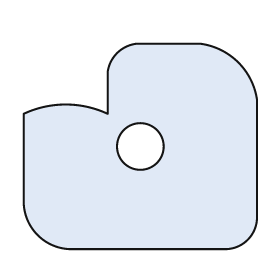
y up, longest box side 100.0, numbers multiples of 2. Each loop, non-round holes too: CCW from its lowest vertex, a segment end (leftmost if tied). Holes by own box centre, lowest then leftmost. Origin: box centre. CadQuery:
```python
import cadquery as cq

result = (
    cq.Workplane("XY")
    .moveTo(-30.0, -44.0)
    .lineTo(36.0, -44.0)
    .threePointArc((46.0, -40.0), (50.0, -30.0))
    .lineTo(50.0, 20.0)
    .threePointArc((42.0, 36.0), (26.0, 44.0))
    .lineTo(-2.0, 44.0)
    .threePointArc((-10.0, 40.0), (-14.0, 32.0))
    .lineTo(-14.0, 14.0)
    .threePointArc((-32.0, 18.0), (-50.0, 14.0))
    .lineTo(-50.0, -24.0)
    .threePointArc((-44.0, -38.0), (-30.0, -44.0))
    .close()
    .moveTo(0.0, 0.0)
    .circle(10.0)
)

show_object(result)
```